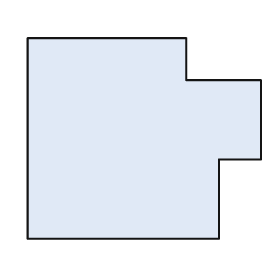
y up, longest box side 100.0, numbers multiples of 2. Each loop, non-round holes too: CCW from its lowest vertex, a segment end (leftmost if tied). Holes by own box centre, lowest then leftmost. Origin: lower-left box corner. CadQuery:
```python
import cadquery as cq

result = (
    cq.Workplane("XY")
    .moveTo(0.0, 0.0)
    .lineTo(82.0, 0.0)
    .lineTo(82.0, 34.0)
    .lineTo(100.0, 34.0)
    .lineTo(100.0, 68.0)
    .lineTo(68.0, 68.0)
    .lineTo(68.0, 86.0)
    .lineTo(0.0, 86.0)
    .close()
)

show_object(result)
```